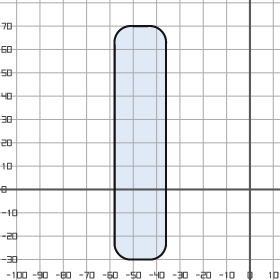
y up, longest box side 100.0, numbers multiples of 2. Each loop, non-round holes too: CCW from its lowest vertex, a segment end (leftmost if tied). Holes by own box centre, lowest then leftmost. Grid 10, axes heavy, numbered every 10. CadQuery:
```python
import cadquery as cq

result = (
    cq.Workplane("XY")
    .moveTo(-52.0, -30.0)
    .lineTo(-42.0, -30.0)
    .threePointArc((-38.0, -28.0), (-36.0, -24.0))
    .lineTo(-36.0, 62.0)
    .threePointArc((-38.0, 68.0), (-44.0, 70.0))
    .lineTo(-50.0, 70.0)
    .threePointArc((-56.0, 68.0), (-58.0, 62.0))
    .lineTo(-58.0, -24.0)
    .threePointArc((-56.0, -28.0), (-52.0, -30.0))
    .close()
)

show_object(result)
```